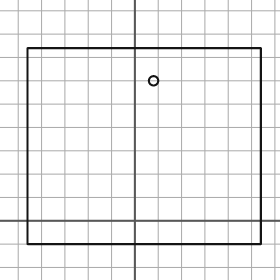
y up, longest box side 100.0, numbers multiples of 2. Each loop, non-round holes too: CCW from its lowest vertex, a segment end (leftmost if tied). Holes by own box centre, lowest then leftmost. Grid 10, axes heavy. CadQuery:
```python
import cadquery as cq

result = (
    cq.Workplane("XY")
    .moveTo(-46.0, -10.0)
    .lineTo(54.0, -10.0)
    .lineTo(54.0, 74.0)
    .lineTo(-46.0, 74.0)
    .close()
    .moveTo(8.0, 60.0)
    .circle(2.0)
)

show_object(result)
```